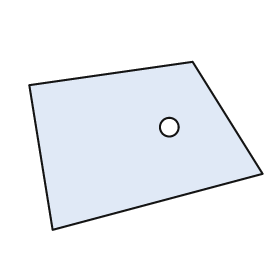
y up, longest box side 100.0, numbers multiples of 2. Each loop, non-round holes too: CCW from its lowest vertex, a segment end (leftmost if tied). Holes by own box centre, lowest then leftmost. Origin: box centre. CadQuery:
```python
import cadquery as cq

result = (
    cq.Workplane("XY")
    .moveTo(-40.0, -36.0)
    .lineTo(50.0, -12.0)
    .lineTo(20.0, 36.0)
    .lineTo(-50.0, 26.0)
    .close()
    .moveTo(10.0, 8.0)
    .circle(4.0)
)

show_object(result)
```